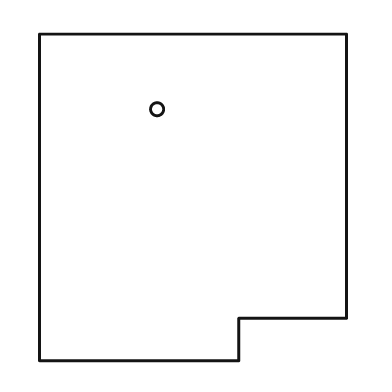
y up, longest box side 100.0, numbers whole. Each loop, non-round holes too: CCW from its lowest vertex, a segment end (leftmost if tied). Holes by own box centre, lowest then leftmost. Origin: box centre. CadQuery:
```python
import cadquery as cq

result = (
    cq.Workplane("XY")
    .moveTo(-47.0, -50.0)
    .lineTo(14.0, -50.0)
    .lineTo(14.0, -37.0)
    .lineTo(47.0, -37.0)
    .lineTo(47.0, 50.0)
    .lineTo(-47.0, 50.0)
    .close()
    .moveTo(-11.0, 27.0)
    .circle(2.0)
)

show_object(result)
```